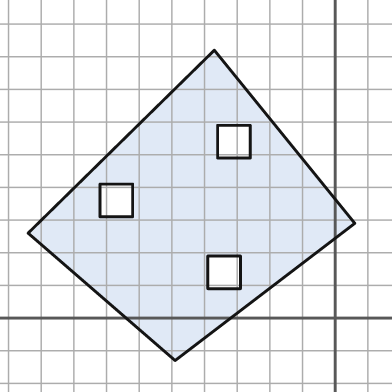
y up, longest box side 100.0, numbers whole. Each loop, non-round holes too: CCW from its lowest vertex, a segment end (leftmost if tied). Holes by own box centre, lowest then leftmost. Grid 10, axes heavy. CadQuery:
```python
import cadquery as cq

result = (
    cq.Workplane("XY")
    .moveTo(-49.0, -13.0)
    .lineTo(6.0, 29.0)
    .lineTo(-37.0, 82.0)
    .lineTo(-94.0, 26.0)
    .close()
    .moveTo(-39.0, 9.0)
    .lineTo(-29.0, 9.0)
    .lineTo(-29.0, 19.0)
    .lineTo(-39.0, 19.0)
    .close()
    .moveTo(-72.0, 31.0)
    .lineTo(-62.0, 31.0)
    .lineTo(-62.0, 41.0)
    .lineTo(-72.0, 41.0)
    .close()
    .moveTo(-36.0, 49.0)
    .lineTo(-26.0, 49.0)
    .lineTo(-26.0, 59.0)
    .lineTo(-36.0, 59.0)
    .close()
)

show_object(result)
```